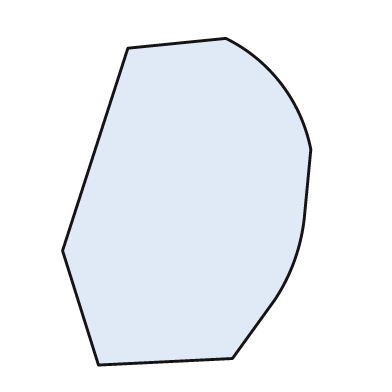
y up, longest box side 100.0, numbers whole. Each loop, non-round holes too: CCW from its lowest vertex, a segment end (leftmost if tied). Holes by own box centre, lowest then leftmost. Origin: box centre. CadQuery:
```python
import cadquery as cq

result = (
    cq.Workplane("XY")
    .moveTo(-27.0, -50.0)
    .lineTo(14.0, -48.0)
    .lineTo(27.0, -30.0)
    .threePointArc((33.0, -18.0), (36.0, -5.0))
    .lineTo(38.0, 16.0)
    .threePointArc((29.0, 36.0), (12.0, 50.0))
    .lineTo(-18.0, 47.0)
    .lineTo(-38.0, -15.0)
    .close()
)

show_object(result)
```